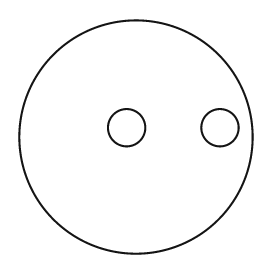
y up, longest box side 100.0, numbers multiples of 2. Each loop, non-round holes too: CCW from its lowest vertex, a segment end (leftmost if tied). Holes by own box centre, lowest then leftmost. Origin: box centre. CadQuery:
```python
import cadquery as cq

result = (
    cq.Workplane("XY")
    .moveTo(0.0, 0.0)
    .circle(50.0)
    .moveTo(-4.0, 4.0)
    .circle(8.0)
    .moveTo(36.0, 4.0)
    .circle(8.0)
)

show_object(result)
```